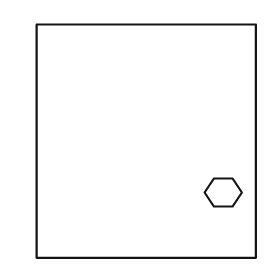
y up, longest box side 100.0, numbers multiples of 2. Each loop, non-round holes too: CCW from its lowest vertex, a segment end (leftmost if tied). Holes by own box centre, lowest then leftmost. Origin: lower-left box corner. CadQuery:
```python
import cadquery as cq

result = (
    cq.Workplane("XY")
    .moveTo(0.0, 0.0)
    .lineTo(94.0, 0.0)
    .lineTo(94.0, 100.0)
    .lineTo(0.0, 100.0)
    .close()
    .moveTo(76.0, 22.0)
    .lineTo(84.0, 22.0)
    .lineTo(88.0, 28.0)
    .lineTo(84.0, 34.0)
    .lineTo(76.0, 34.0)
    .lineTo(72.0, 28.0)
    .close()
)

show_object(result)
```